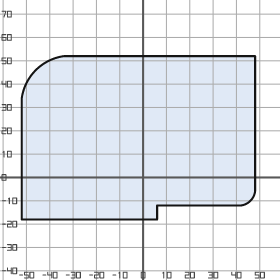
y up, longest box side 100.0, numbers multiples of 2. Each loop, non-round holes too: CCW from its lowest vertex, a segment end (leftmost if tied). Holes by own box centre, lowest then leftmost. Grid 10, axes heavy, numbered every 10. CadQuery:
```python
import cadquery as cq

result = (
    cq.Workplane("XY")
    .moveTo(-52.0, -18.0)
    .lineTo(6.0, -18.0)
    .lineTo(6.0, -12.0)
    .lineTo(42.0, -12.0)
    .threePointArc((46.0, -10.0), (48.0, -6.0))
    .lineTo(48.0, 52.0)
    .lineTo(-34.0, 52.0)
    .threePointArc((-46.0, 46.0), (-52.0, 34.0))
    .close()
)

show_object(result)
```